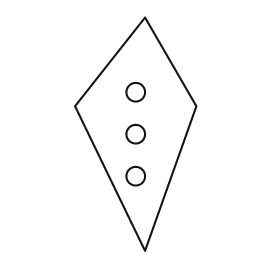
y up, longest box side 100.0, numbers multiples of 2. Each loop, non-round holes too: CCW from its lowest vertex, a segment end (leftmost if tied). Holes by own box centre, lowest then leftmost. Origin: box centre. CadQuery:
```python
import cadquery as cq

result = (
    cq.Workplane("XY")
    .moveTo(4.0, -50.0)
    .lineTo(26.0, 12.0)
    .lineTo(4.0, 50.0)
    .lineTo(-26.0, 12.0)
    .close()
    .moveTo(0.0, -18.0)
    .circle(4.0)
    .moveTo(0.0, 0.0)
    .circle(4.0)
    .moveTo(0.0, 18.0)
    .circle(4.0)
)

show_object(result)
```